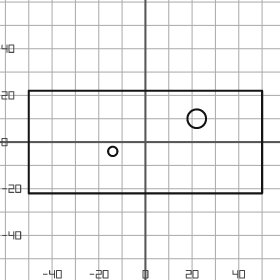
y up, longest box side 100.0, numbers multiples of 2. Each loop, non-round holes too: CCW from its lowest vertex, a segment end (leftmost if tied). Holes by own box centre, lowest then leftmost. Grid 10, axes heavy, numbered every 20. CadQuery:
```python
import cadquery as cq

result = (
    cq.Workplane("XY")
    .moveTo(-50.0, -22.0)
    .lineTo(50.0, -22.0)
    .lineTo(50.0, 22.0)
    .lineTo(-50.0, 22.0)
    .close()
    .moveTo(-14.0, -4.0)
    .circle(2.0)
    .moveTo(22.0, 10.0)
    .circle(4.0)
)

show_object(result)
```